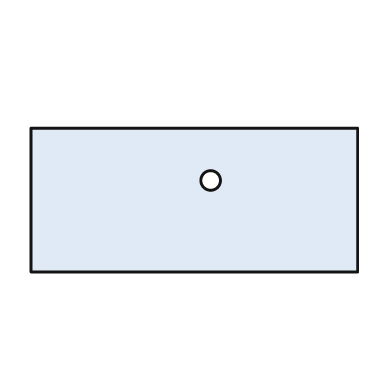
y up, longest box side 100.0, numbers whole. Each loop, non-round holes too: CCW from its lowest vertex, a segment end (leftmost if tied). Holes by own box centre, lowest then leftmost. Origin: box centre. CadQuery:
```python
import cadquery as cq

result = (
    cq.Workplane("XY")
    .moveTo(-50.0, -22.0)
    .lineTo(50.0, -22.0)
    .lineTo(50.0, 22.0)
    .lineTo(-50.0, 22.0)
    .close()
    .moveTo(5.0, 6.0)
    .circle(3.0)
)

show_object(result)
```